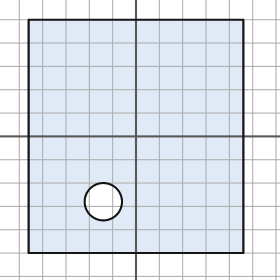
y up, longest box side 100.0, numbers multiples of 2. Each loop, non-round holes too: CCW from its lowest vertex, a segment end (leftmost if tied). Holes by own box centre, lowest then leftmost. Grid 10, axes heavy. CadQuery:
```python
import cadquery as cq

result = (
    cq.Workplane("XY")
    .moveTo(-46.0, -50.0)
    .lineTo(46.0, -50.0)
    .lineTo(46.0, 50.0)
    .lineTo(-46.0, 50.0)
    .close()
    .moveTo(-14.0, -28.0)
    .circle(8.0)
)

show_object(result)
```